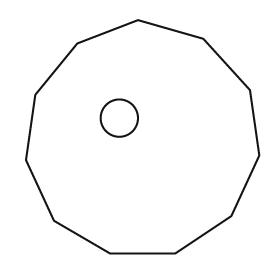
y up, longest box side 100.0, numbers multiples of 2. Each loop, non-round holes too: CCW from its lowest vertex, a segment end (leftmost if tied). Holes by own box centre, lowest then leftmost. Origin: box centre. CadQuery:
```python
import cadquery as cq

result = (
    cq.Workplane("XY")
    .moveTo(-14.0, -50.0)
    .lineTo(14.0, -50.0)
    .lineTo(38.0, -34.0)
    .lineTo(50.0, -8.0)
    .lineTo(46.0, 20.0)
    .lineTo(26.0, 42.0)
    .lineTo(-2.0, 50.0)
    .lineTo(-28.0, 40.0)
    .lineTo(-46.0, 18.0)
    .lineTo(-50.0, -10.0)
    .lineTo(-38.0, -36.0)
    .close()
    .moveTo(-10.0, 8.0)
    .circle(8.0)
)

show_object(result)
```